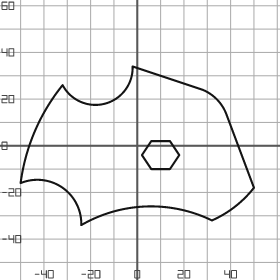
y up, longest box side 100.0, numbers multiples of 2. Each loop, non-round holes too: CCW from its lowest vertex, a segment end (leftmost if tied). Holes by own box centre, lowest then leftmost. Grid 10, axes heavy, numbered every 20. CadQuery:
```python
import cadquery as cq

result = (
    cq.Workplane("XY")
    .moveTo(-24.0, -34.0)
    .threePointArc((4.0, -26.0), (32.0, -32.0))
    .threePointArc((42.0, -26.0), (50.0, -18.0))
    .lineTo(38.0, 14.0)
    .threePointArc((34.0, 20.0), (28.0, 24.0))
    .lineTo(-2.0, 34.0)
    .threePointArc((-14.0, 18.0), (-32.0, 26.0))
    .threePointArc((-44.0, 6.0), (-50.0, -16.0))
    .threePointArc((-32.0, -18.0), (-24.0, -34.0))
    .close()
    .moveTo(6.0, -10.0)
    .lineTo(14.0, -10.0)
    .lineTo(18.0, -4.0)
    .lineTo(14.0, 2.0)
    .lineTo(6.0, 2.0)
    .lineTo(2.0, -4.0)
    .close()
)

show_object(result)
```